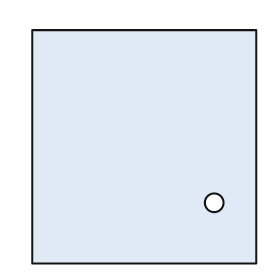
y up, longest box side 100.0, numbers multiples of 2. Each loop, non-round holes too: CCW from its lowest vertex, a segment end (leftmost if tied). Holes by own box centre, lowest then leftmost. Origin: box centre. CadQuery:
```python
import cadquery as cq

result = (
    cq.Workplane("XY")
    .moveTo(-48.0, -50.0)
    .lineTo(48.0, -50.0)
    .lineTo(48.0, 50.0)
    .lineTo(-48.0, 50.0)
    .close()
    .moveTo(30.0, -24.0)
    .circle(4.0)
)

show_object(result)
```